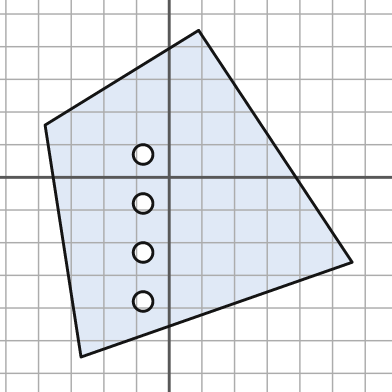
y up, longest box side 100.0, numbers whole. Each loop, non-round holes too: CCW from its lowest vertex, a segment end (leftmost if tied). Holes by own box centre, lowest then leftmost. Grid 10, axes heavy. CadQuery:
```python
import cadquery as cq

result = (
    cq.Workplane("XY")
    .moveTo(-27.0, -55.0)
    .lineTo(56.0, -26.0)
    .lineTo(9.0, 45.0)
    .lineTo(-38.0, 16.0)
    .close()
    .moveTo(-8.0, -38.0)
    .circle(3.0)
    .moveTo(-8.0, -23.0)
    .circle(3.0)
    .moveTo(-8.0, -8.0)
    .circle(3.0)
    .moveTo(-8.0, 7.0)
    .circle(3.0)
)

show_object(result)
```